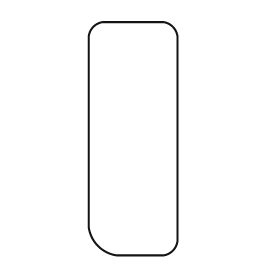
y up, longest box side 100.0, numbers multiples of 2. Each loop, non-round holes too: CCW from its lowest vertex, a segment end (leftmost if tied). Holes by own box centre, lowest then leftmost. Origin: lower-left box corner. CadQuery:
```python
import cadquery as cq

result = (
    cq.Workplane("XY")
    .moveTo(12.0, 0.0)
    .lineTo(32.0, 0.0)
    .threePointArc((36.0, 2.0), (38.0, 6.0))
    .lineTo(38.0, 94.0)
    .threePointArc((36.0, 98.0), (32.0, 100.0))
    .lineTo(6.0, 100.0)
    .threePointArc((2.0, 98.0), (0.0, 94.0))
    .lineTo(0.0, 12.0)
    .threePointArc((4.0, 4.0), (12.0, 0.0))
    .close()
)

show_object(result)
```